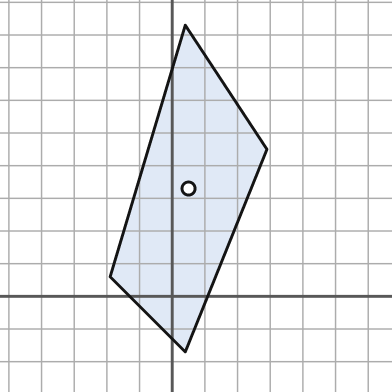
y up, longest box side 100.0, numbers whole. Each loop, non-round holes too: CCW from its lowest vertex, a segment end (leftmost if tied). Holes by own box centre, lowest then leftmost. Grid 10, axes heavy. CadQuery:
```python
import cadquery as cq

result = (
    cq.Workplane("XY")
    .moveTo(4.0, -17.0)
    .lineTo(29.0, 45.0)
    .lineTo(4.0, 83.0)
    .lineTo(-19.0, 6.0)
    .close()
    .moveTo(5.0, 33.0)
    .circle(2.0)
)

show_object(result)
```